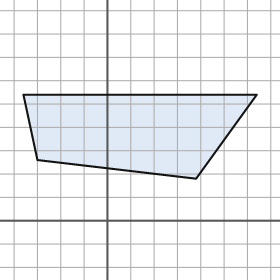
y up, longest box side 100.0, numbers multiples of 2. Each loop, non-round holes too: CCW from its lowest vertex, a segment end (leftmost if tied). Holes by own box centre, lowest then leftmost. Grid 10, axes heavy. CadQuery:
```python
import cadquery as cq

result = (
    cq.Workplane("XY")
    .moveTo(38.0, 18.0)
    .lineTo(64.0, 54.0)
    .lineTo(-36.0, 54.0)
    .lineTo(-30.0, 26.0)
    .close()
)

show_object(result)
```